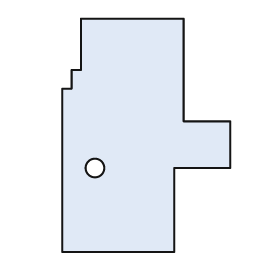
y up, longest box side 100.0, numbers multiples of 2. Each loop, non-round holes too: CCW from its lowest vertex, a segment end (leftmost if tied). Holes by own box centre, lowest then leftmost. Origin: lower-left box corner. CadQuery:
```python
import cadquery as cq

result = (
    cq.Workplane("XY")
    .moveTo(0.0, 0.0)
    .lineTo(48.0, 0.0)
    .lineTo(48.0, 36.0)
    .lineTo(72.0, 36.0)
    .lineTo(72.0, 56.0)
    .lineTo(52.0, 56.0)
    .lineTo(52.0, 100.0)
    .lineTo(8.0, 100.0)
    .lineTo(8.0, 78.0)
    .lineTo(4.0, 78.0)
    .lineTo(4.0, 70.0)
    .lineTo(0.0, 70.0)
    .close()
    .moveTo(14.0, 36.0)
    .circle(4.0)
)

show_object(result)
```